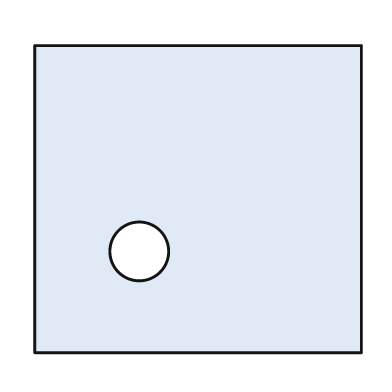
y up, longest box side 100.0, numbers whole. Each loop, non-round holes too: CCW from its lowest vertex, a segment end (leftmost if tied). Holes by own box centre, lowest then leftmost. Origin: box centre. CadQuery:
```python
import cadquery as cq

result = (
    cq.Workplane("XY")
    .moveTo(-50.0, -47.0)
    .lineTo(50.0, -47.0)
    .lineTo(50.0, 47.0)
    .lineTo(-50.0, 47.0)
    .close()
    .moveTo(-18.0, -16.0)
    .circle(9.0)
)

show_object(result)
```